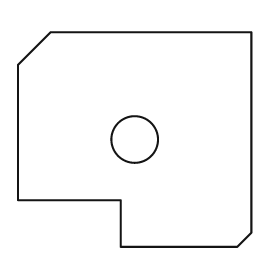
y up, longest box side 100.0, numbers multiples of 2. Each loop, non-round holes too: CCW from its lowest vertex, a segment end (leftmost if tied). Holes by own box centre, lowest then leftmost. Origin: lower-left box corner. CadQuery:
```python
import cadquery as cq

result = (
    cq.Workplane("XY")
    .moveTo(44.0, 0.0)
    .lineTo(94.0, 0.0)
    .lineTo(100.0, 6.0)
    .lineTo(100.0, 92.0)
    .lineTo(14.0, 92.0)
    .lineTo(0.0, 78.0)
    .lineTo(0.0, 20.0)
    .lineTo(44.0, 20.0)
    .close()
    .moveTo(50.0, 46.0)
    .circle(10.0)
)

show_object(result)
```